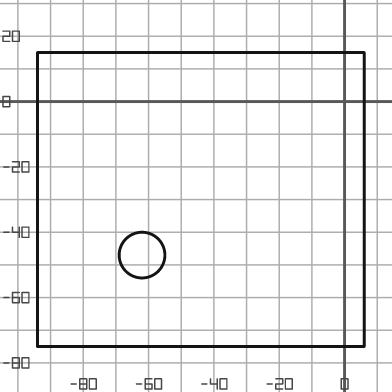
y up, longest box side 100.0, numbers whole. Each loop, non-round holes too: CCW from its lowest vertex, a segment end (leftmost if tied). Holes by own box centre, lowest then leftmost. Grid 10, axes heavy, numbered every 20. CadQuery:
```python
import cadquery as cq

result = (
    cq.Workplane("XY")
    .moveTo(-94.0, -75.0)
    .lineTo(6.0, -75.0)
    .lineTo(6.0, 15.0)
    .lineTo(-94.0, 15.0)
    .close()
    .moveTo(-62.0, -47.0)
    .circle(7.0)
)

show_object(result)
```